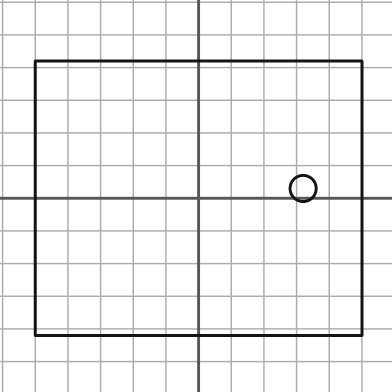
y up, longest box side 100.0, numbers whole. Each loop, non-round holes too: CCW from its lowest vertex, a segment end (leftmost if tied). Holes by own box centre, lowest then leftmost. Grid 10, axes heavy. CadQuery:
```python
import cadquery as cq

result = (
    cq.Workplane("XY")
    .moveTo(-50.0, -42.0)
    .lineTo(50.0, -42.0)
    .lineTo(50.0, 42.0)
    .lineTo(-50.0, 42.0)
    .close()
    .moveTo(32.0, 3.0)
    .circle(4.0)
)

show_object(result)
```